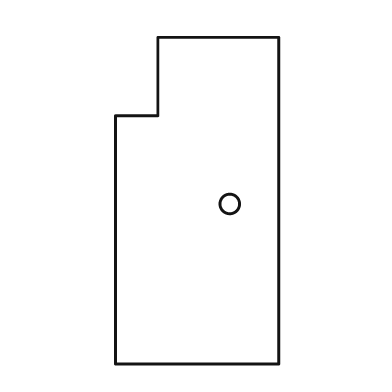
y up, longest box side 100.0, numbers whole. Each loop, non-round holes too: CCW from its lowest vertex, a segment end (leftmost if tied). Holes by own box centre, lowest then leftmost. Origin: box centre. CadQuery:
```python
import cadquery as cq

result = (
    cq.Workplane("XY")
    .moveTo(-25.0, -50.0)
    .lineTo(25.0, -50.0)
    .lineTo(25.0, 50.0)
    .lineTo(-12.0, 50.0)
    .lineTo(-12.0, 26.0)
    .lineTo(-25.0, 26.0)
    .close()
    .moveTo(10.0, -1.0)
    .circle(3.0)
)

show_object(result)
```